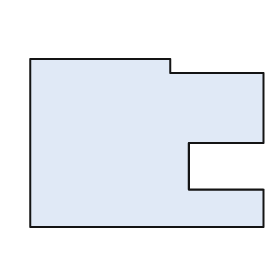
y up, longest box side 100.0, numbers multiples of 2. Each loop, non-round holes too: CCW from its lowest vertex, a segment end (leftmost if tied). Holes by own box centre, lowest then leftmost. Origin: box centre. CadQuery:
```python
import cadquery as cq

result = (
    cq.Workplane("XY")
    .moveTo(-50.0, -36.0)
    .lineTo(50.0, -36.0)
    .lineTo(50.0, -20.0)
    .lineTo(18.0, -20.0)
    .lineTo(18.0, 0.0)
    .lineTo(50.0, 0.0)
    .lineTo(50.0, 30.0)
    .lineTo(10.0, 30.0)
    .lineTo(10.0, 36.0)
    .lineTo(-50.0, 36.0)
    .close()
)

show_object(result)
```